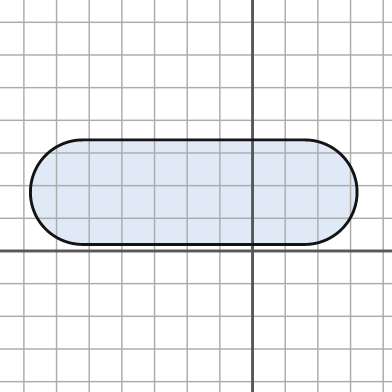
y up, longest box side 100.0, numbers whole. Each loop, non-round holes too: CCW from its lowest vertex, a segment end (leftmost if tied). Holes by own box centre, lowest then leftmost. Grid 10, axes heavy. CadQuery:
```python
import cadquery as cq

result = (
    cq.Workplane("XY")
    .moveTo(-52.0, 2.0)
    .lineTo(16.0, 2.0)
    .threePointArc((32.0, 18.0), (16.0, 34.0))
    .lineTo(-52.0, 34.0)
    .threePointArc((-68.0, 18.0), (-52.0, 2.0))
    .close()
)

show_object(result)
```